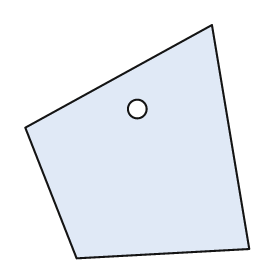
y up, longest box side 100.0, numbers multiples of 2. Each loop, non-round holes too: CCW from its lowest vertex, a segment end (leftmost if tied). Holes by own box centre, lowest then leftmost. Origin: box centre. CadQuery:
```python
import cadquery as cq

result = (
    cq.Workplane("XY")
    .moveTo(-26.0, -50.0)
    .lineTo(48.0, -46.0)
    .lineTo(32.0, 50.0)
    .lineTo(-48.0, 6.0)
    .close()
    .moveTo(0.0, 14.0)
    .circle(4.0)
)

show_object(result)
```